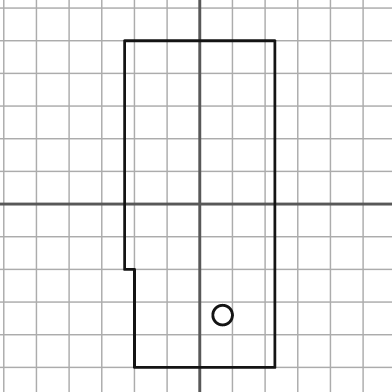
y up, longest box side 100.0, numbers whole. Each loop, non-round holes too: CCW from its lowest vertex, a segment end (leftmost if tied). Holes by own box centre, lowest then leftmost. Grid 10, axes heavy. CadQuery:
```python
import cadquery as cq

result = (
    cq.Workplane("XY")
    .moveTo(-20.0, -50.0)
    .lineTo(23.0, -50.0)
    .lineTo(23.0, 50.0)
    .lineTo(-23.0, 50.0)
    .lineTo(-23.0, -20.0)
    .lineTo(-20.0, -20.0)
    .close()
    .moveTo(7.0, -34.0)
    .circle(3.0)
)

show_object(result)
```